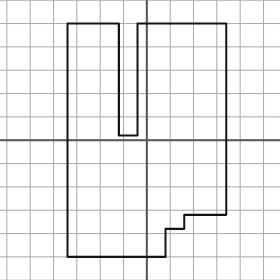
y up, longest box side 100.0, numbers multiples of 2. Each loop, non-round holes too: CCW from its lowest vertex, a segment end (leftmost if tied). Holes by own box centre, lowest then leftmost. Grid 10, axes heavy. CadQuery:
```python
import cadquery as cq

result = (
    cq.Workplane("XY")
    .moveTo(-34.0, -50.0)
    .lineTo(8.0, -50.0)
    .lineTo(8.0, -38.0)
    .lineTo(16.0, -38.0)
    .lineTo(16.0, -32.0)
    .lineTo(34.0, -32.0)
    .lineTo(34.0, 50.0)
    .lineTo(-4.0, 50.0)
    .lineTo(-4.0, 2.0)
    .lineTo(-12.0, 2.0)
    .lineTo(-12.0, 50.0)
    .lineTo(-34.0, 50.0)
    .close()
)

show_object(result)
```